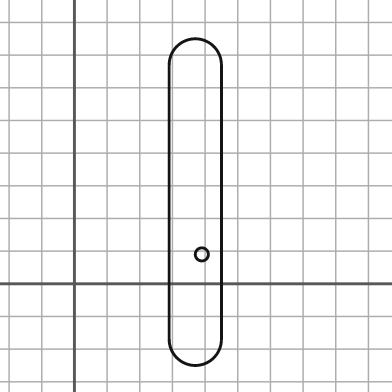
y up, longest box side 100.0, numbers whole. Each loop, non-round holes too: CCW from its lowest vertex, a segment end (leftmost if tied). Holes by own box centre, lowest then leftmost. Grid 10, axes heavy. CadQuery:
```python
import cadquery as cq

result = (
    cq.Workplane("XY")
    .moveTo(29.0, -17.0)
    .threePointArc((37.0, -25.0), (45.0, -17.0))
    .lineTo(45.0, 67.0)
    .threePointArc((37.0, 75.0), (29.0, 67.0))
    .close()
    .moveTo(39.0, 9.0)
    .circle(2.0)
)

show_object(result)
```